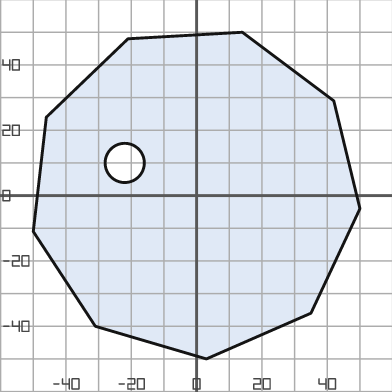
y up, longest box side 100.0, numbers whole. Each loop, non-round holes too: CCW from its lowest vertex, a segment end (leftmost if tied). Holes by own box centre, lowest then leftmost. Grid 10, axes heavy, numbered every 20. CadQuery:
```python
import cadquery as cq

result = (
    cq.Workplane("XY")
    .moveTo(3.0, -50.0)
    .lineTo(35.0, -36.0)
    .lineTo(50.0, -4.0)
    .lineTo(42.0, 29.0)
    .lineTo(14.0, 50.0)
    .lineTo(-21.0, 48.0)
    .lineTo(-46.0, 24.0)
    .lineTo(-50.0, -11.0)
    .lineTo(-31.0, -40.0)
    .close()
    .moveTo(-22.0, 10.0)
    .circle(6.0)
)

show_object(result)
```